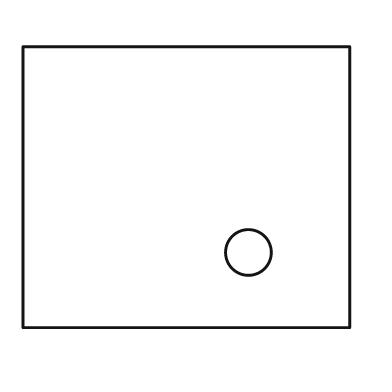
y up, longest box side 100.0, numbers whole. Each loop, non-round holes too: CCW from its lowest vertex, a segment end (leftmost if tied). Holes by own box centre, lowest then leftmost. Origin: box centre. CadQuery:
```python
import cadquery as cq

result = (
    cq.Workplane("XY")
    .moveTo(-50.0, -43.0)
    .lineTo(50.0, -43.0)
    .lineTo(50.0, 43.0)
    .lineTo(-50.0, 43.0)
    .close()
    .moveTo(19.0, -20.0)
    .circle(7.0)
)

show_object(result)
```